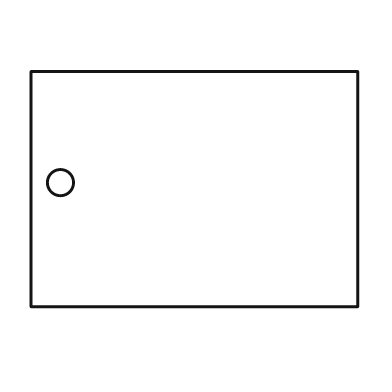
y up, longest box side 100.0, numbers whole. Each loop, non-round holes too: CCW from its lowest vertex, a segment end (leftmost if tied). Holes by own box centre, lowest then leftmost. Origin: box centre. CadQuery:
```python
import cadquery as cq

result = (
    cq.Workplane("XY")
    .moveTo(-50.0, -36.0)
    .lineTo(50.0, -36.0)
    .lineTo(50.0, 36.0)
    .lineTo(-50.0, 36.0)
    .close()
    .moveTo(-41.0, 2.0)
    .circle(4.0)
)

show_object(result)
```